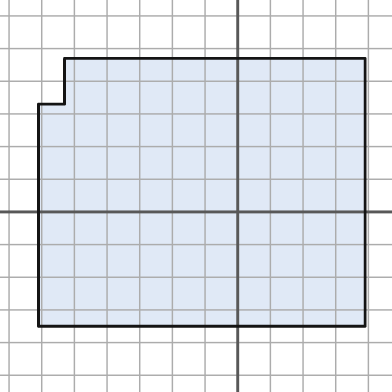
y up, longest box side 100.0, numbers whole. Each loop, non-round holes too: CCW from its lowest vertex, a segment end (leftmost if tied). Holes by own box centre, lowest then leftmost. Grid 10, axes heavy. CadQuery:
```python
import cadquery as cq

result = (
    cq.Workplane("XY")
    .moveTo(-61.0, -35.0)
    .lineTo(39.0, -35.0)
    .lineTo(39.0, 47.0)
    .lineTo(-53.0, 47.0)
    .lineTo(-53.0, 33.0)
    .lineTo(-61.0, 33.0)
    .close()
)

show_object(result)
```